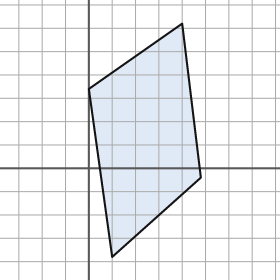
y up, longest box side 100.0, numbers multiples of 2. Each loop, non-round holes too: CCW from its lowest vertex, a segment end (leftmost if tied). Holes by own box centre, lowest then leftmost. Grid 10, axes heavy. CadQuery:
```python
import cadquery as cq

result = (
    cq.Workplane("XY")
    .moveTo(10.0, -38.0)
    .lineTo(48.0, -4.0)
    .lineTo(40.0, 62.0)
    .lineTo(0.0, 34.0)
    .close()
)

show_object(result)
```